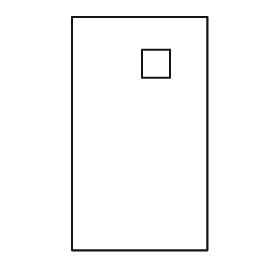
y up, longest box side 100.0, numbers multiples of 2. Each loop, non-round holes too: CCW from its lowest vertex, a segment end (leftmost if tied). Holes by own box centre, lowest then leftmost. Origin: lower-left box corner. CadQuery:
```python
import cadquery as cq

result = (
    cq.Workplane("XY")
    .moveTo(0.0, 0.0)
    .lineTo(58.0, 0.0)
    .lineTo(58.0, 100.0)
    .lineTo(0.0, 100.0)
    .close()
    .moveTo(30.0, 74.0)
    .lineTo(42.0, 74.0)
    .lineTo(42.0, 86.0)
    .lineTo(30.0, 86.0)
    .close()
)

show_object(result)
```